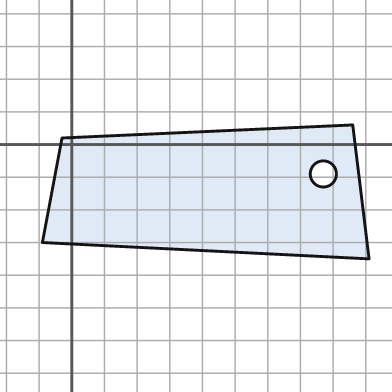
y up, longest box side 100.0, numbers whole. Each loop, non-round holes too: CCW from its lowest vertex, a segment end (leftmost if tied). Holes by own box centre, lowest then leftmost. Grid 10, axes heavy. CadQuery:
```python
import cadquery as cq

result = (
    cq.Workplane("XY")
    .moveTo(91.0, -35.0)
    .lineTo(86.0, 6.0)
    .lineTo(-3.0, 2.0)
    .lineTo(-9.0, -30.0)
    .close()
    .moveTo(77.0, -9.0)
    .circle(4.0)
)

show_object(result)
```